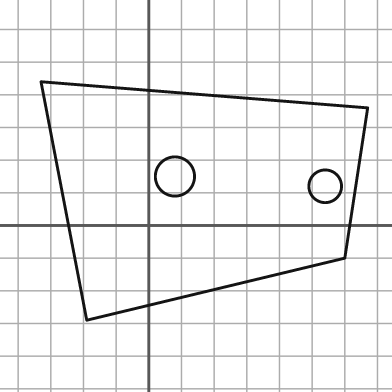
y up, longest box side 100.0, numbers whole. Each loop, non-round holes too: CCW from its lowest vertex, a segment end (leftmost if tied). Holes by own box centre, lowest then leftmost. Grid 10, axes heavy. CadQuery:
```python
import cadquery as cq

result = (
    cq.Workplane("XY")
    .moveTo(-19.0, -29.0)
    .lineTo(60.0, -10.0)
    .lineTo(67.0, 36.0)
    .lineTo(-33.0, 44.0)
    .close()
    .moveTo(54.0, 12.0)
    .circle(5.0)
    .moveTo(8.0, 15.0)
    .circle(6.0)
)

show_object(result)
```